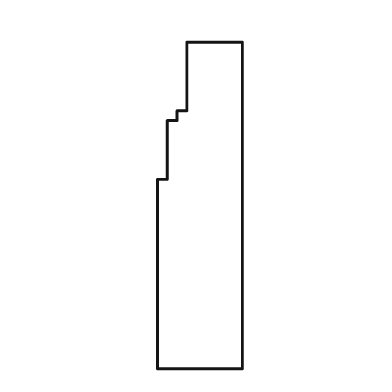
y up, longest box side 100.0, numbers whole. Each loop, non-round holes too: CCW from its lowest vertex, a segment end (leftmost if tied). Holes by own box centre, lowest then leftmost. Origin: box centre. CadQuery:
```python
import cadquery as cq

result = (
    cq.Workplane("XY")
    .moveTo(-13.0, -50.0)
    .lineTo(13.0, -50.0)
    .lineTo(13.0, 50.0)
    .lineTo(-4.0, 50.0)
    .lineTo(-4.0, 29.0)
    .lineTo(-7.0, 29.0)
    .lineTo(-7.0, 26.0)
    .lineTo(-10.0, 26.0)
    .lineTo(-10.0, 8.0)
    .lineTo(-13.0, 8.0)
    .close()
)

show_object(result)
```